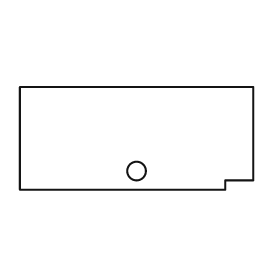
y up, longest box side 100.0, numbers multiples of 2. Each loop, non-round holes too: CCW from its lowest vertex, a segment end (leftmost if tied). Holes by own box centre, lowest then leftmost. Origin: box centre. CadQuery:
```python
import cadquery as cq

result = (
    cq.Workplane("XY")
    .moveTo(-50.0, -22.0)
    .lineTo(38.0, -22.0)
    .lineTo(38.0, -18.0)
    .lineTo(50.0, -18.0)
    .lineTo(50.0, 22.0)
    .lineTo(-50.0, 22.0)
    .close()
    .moveTo(0.0, -14.0)
    .circle(4.0)
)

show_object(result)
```